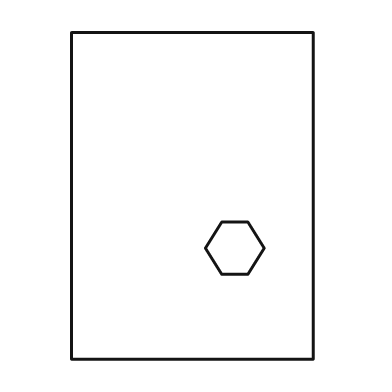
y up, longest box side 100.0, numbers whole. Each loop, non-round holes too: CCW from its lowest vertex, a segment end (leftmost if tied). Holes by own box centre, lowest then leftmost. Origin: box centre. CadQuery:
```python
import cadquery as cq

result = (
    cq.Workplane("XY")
    .moveTo(-37.0, -50.0)
    .lineTo(37.0, -50.0)
    .lineTo(37.0, 50.0)
    .lineTo(-37.0, 50.0)
    .close()
    .moveTo(9.0, -24.0)
    .lineTo(17.0, -24.0)
    .lineTo(22.0, -16.0)
    .lineTo(17.0, -8.0)
    .lineTo(9.0, -8.0)
    .lineTo(4.0, -16.0)
    .close()
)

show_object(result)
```